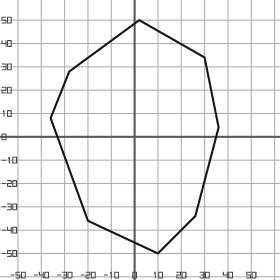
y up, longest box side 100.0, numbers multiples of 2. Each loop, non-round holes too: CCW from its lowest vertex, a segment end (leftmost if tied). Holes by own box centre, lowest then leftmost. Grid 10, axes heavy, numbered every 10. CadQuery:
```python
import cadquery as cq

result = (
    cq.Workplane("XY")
    .moveTo(10.0, -50.0)
    .lineTo(26.0, -34.0)
    .lineTo(36.0, 4.0)
    .lineTo(30.0, 34.0)
    .lineTo(2.0, 50.0)
    .lineTo(-28.0, 28.0)
    .lineTo(-36.0, 8.0)
    .lineTo(-20.0, -36.0)
    .close()
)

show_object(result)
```